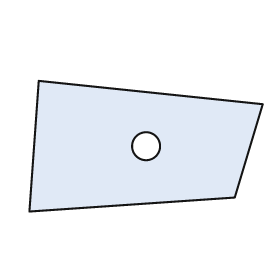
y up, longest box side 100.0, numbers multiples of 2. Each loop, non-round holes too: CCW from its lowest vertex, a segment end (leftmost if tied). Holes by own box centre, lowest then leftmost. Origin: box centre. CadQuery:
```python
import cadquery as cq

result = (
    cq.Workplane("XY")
    .moveTo(-50.0, -28.0)
    .lineTo(38.0, -22.0)
    .lineTo(50.0, 18.0)
    .lineTo(-46.0, 28.0)
    .close()
    .moveTo(0.0, 0.0)
    .circle(6.0)
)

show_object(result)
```